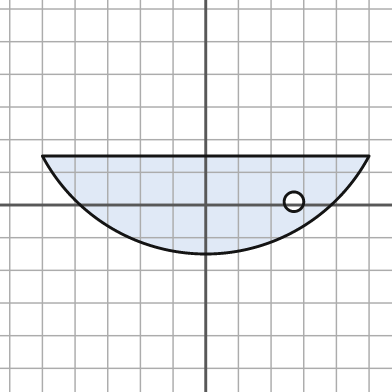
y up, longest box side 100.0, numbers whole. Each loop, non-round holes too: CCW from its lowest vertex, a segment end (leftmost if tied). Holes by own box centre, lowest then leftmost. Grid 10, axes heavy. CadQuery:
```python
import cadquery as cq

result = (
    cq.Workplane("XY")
    .moveTo(-50.0, 15.0)
    .threePointArc((0.0, -15.0), (50.0, 15.0))
    .close()
    .moveTo(27.0, 1.0)
    .circle(3.0)
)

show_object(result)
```